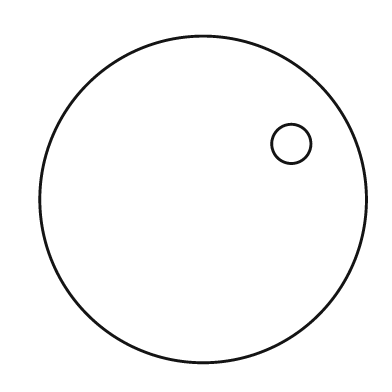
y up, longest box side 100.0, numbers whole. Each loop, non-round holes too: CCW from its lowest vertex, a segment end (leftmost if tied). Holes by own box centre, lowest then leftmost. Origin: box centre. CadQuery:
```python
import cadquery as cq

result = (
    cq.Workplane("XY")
    .moveTo(0.0, 0.0)
    .circle(50.0)
    .moveTo(27.0, 17.0)
    .circle(6.0)
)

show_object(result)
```